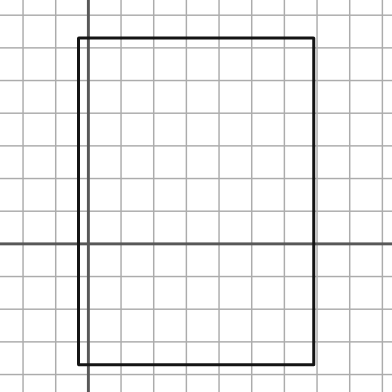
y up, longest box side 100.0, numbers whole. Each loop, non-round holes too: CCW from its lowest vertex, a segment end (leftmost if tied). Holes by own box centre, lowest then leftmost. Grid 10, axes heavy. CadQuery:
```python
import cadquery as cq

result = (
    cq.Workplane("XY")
    .moveTo(-3.0, -37.0)
    .lineTo(69.0, -37.0)
    .lineTo(69.0, 63.0)
    .lineTo(-3.0, 63.0)
    .close()
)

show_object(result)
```